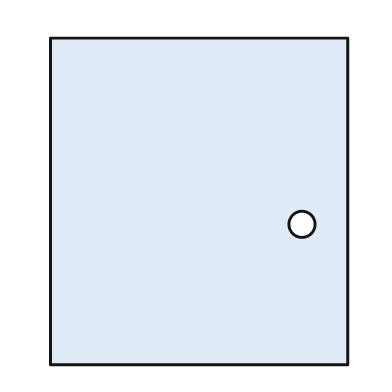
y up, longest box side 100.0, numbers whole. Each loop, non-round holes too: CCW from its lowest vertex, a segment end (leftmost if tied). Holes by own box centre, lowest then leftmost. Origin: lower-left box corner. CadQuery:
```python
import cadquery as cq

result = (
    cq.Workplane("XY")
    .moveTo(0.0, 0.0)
    .lineTo(91.0, 0.0)
    .lineTo(91.0, 100.0)
    .lineTo(0.0, 100.0)
    .close()
    .moveTo(77.0, 43.0)
    .circle(4.0)
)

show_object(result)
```